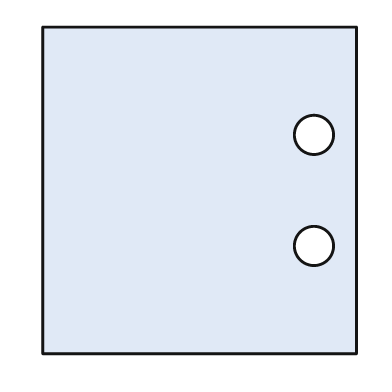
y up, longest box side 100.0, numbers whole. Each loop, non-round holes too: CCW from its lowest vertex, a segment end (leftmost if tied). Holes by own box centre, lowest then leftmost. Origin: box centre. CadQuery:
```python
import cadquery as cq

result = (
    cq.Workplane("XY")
    .moveTo(-48.0, -50.0)
    .lineTo(48.0, -50.0)
    .lineTo(48.0, 50.0)
    .lineTo(-48.0, 50.0)
    .close()
    .moveTo(35.0, -17.0)
    .circle(6.0)
    .moveTo(35.0, 17.0)
    .circle(6.0)
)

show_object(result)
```